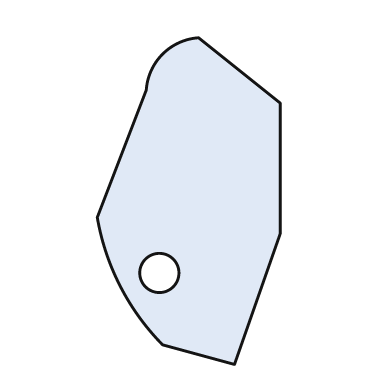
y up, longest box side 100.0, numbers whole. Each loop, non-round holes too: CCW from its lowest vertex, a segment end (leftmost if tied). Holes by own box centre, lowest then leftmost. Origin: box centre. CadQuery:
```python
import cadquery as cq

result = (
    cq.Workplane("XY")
    .moveTo(14.0, -50.0)
    .lineTo(28.0, -10.0)
    .lineTo(28.0, 30.0)
    .lineTo(3.0, 50.0)
    .threePointArc((-8.0, 45.0), (-13.0, 34.0))
    .lineTo(-28.0, -5.0)
    .threePointArc((-21.0, -26.0), (-8.0, -44.0))
    .close()
    .moveTo(-9.0, -22.0)
    .circle(6.0)
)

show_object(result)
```